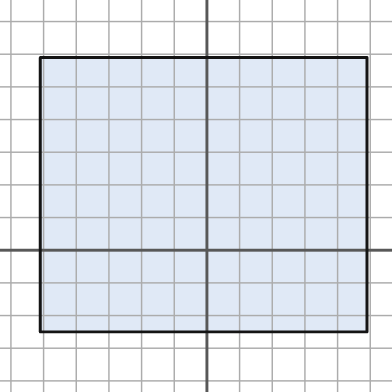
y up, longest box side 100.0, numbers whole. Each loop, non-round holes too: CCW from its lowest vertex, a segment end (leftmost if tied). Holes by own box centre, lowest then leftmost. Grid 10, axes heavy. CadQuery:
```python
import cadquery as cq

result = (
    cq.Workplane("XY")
    .moveTo(-51.0, -25.0)
    .lineTo(49.0, -25.0)
    .lineTo(49.0, 59.0)
    .lineTo(-51.0, 59.0)
    .close()
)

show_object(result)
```